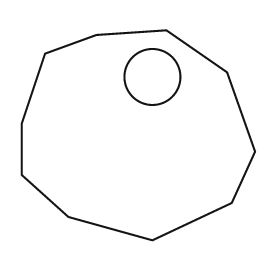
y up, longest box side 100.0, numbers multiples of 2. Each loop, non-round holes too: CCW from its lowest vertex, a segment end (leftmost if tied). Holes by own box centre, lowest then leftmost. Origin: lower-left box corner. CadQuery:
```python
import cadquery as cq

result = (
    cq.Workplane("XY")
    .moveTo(56.0, 0.0)
    .lineTo(90.0, 16.0)
    .lineTo(100.0, 38.0)
    .lineTo(88.0, 72.0)
    .lineTo(62.0, 90.0)
    .lineTo(32.0, 88.0)
    .lineTo(10.0, 80.0)
    .lineTo(0.0, 50.0)
    .lineTo(0.0, 28.0)
    .lineTo(20.0, 10.0)
    .close()
    .moveTo(56.0, 70.0)
    .circle(12.0)
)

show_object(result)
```